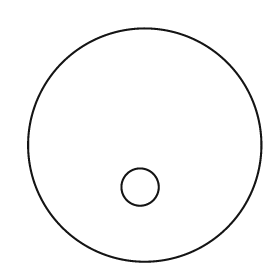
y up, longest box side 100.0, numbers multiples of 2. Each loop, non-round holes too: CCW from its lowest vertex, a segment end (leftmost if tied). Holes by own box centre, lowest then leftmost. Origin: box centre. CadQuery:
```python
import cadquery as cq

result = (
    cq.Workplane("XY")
    .moveTo(0.0, 0.0)
    .circle(50.0)
    .moveTo(-2.0, -18.0)
    .circle(8.0)
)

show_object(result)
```